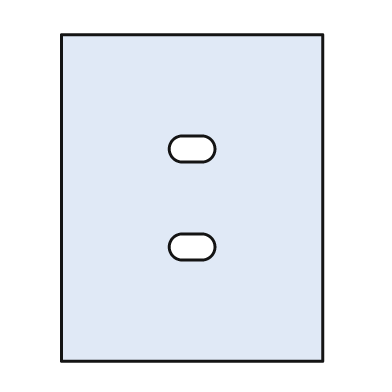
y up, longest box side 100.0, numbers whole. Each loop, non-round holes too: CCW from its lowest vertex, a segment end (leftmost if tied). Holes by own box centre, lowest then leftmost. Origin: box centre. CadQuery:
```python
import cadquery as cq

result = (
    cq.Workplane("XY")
    .moveTo(-40.0, -50.0)
    .lineTo(40.0, -50.0)
    .lineTo(40.0, 50.0)
    .lineTo(-40.0, 50.0)
    .close()
    .moveTo(-3.0, -19.0)
    .lineTo(3.0, -19.0)
    .threePointArc((7.0, -15.0), (3.0, -11.0))
    .lineTo(-3.0, -11.0)
    .threePointArc((-7.0, -15.0), (-3.0, -19.0))
    .close()
    .moveTo(-3.0, 11.0)
    .lineTo(3.0, 11.0)
    .threePointArc((7.0, 15.0), (3.0, 19.0))
    .lineTo(-3.0, 19.0)
    .threePointArc((-7.0, 15.0), (-3.0, 11.0))
    .close()
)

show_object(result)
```